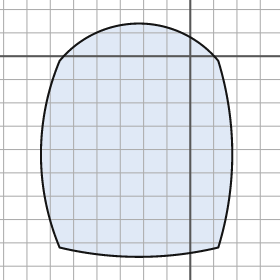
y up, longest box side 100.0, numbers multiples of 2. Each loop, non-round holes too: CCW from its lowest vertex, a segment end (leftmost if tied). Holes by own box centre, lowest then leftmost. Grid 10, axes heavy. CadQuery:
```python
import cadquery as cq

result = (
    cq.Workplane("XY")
    .moveTo(-56.0, -82.0)
    .threePointArc((-22.0, -86.0), (12.0, -82.0))
    .threePointArc((18.0, -42.0), (12.0, -2.0))
    .threePointArc((-22.0, 14.0), (-56.0, -2.0))
    .threePointArc((-64.0, -42.0), (-56.0, -82.0))
    .close()
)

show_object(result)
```